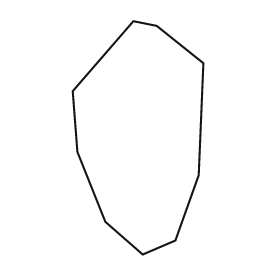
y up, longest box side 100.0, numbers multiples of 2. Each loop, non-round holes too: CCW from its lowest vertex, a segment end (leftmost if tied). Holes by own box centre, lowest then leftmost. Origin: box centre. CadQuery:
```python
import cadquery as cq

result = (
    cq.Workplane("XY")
    .moveTo(2.0, -50.0)
    .lineTo(16.0, -44.0)
    .lineTo(26.0, -16.0)
    .lineTo(28.0, 32.0)
    .lineTo(8.0, 48.0)
    .lineTo(-2.0, 50.0)
    .lineTo(-28.0, 20.0)
    .lineTo(-26.0, -6.0)
    .lineTo(-14.0, -36.0)
    .close()
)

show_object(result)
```